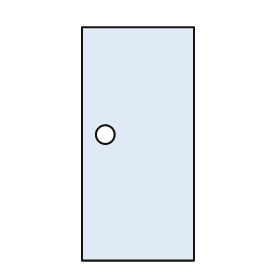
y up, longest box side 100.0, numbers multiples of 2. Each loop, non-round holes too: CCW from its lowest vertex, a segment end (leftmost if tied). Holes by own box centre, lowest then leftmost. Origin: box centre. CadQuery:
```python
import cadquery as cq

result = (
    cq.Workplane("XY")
    .moveTo(-24.0, -50.0)
    .lineTo(24.0, -50.0)
    .lineTo(24.0, 50.0)
    .lineTo(-24.0, 50.0)
    .close()
    .moveTo(-14.0, 4.0)
    .circle(4.0)
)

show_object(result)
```